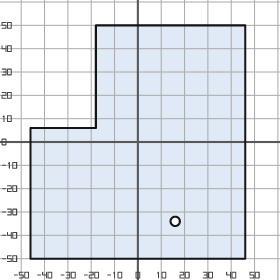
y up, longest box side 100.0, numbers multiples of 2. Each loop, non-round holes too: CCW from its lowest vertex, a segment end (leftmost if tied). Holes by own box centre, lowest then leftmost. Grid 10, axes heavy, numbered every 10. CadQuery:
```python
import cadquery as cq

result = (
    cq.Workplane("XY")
    .moveTo(-46.0, -50.0)
    .lineTo(46.0, -50.0)
    .lineTo(46.0, 50.0)
    .lineTo(-18.0, 50.0)
    .lineTo(-18.0, 6.0)
    .lineTo(-46.0, 6.0)
    .close()
    .moveTo(16.0, -34.0)
    .circle(2.0)
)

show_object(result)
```